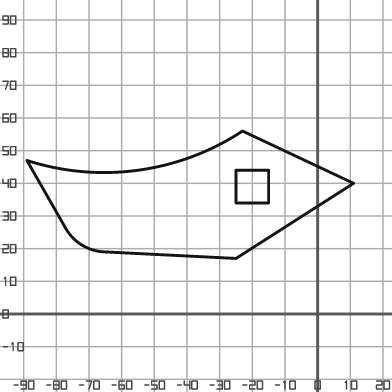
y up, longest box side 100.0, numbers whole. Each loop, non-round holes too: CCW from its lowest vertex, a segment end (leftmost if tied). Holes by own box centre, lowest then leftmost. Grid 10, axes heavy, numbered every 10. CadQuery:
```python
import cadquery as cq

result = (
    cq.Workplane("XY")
    .moveTo(-25.0, 17.0)
    .lineTo(11.0, 40.0)
    .lineTo(-23.0, 56.0)
    .threePointArc((-55.0, 44.0), (-89.0, 47.0))
    .lineTo(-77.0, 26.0)
    .threePointArc((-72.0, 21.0), (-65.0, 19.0))
    .close()
    .moveTo(-25.0, 34.0)
    .lineTo(-15.0, 34.0)
    .lineTo(-15.0, 44.0)
    .lineTo(-25.0, 44.0)
    .close()
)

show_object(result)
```